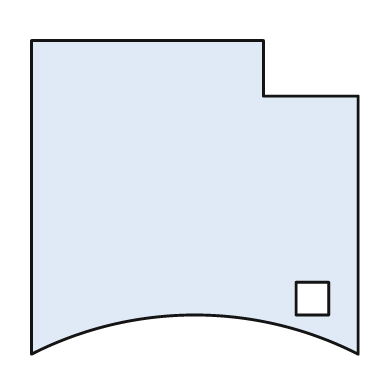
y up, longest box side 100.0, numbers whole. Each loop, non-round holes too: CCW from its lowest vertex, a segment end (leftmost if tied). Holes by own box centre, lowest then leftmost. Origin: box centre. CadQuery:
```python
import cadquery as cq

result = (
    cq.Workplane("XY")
    .moveTo(-50.0, -48.0)
    .threePointArc((0.0, -36.0), (50.0, -48.0))
    .lineTo(50.0, 31.0)
    .lineTo(21.0, 31.0)
    .lineTo(21.0, 48.0)
    .lineTo(-50.0, 48.0)
    .close()
    .moveTo(31.0, -36.0)
    .lineTo(41.0, -36.0)
    .lineTo(41.0, -26.0)
    .lineTo(31.0, -26.0)
    .close()
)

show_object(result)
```